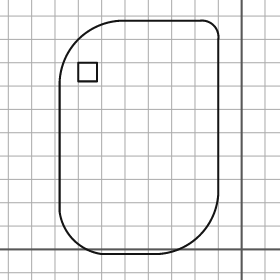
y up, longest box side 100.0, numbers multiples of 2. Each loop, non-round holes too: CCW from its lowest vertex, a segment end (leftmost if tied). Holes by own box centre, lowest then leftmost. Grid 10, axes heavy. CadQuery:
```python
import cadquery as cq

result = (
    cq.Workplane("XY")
    .moveTo(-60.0, -2.0)
    .lineTo(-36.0, -2.0)
    .threePointArc((-18.0, 6.0), (-10.0, 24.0))
    .lineTo(-10.0, 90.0)
    .threePointArc((-12.0, 96.0), (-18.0, 98.0))
    .lineTo(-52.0, 98.0)
    .threePointArc((-70.0, 90.0), (-78.0, 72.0))
    .lineTo(-78.0, 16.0)
    .threePointArc((-72.0, 4.0), (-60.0, -2.0))
    .close()
    .moveTo(-70.0, 72.0)
    .lineTo(-62.0, 72.0)
    .lineTo(-62.0, 80.0)
    .lineTo(-70.0, 80.0)
    .close()
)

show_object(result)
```